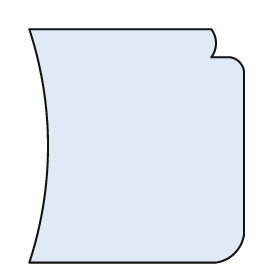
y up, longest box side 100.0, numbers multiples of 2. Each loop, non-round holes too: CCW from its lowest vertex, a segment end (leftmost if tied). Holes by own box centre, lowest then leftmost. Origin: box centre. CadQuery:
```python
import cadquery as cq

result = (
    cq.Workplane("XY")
    .moveTo(-46.0, -50.0)
    .lineTo(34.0, -50.0)
    .threePointArc((42.0, -46.0), (46.0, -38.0))
    .lineTo(46.0, 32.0)
    .threePointArc((44.0, 36.0), (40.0, 38.0))
    .lineTo(32.0, 38.0)
    .threePointArc((34.0, 44.0), (32.0, 50.0))
    .lineTo(-46.0, 50.0)
    .threePointArc((-38.0, 0.0), (-46.0, -50.0))
    .close()
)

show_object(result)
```